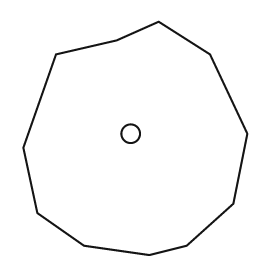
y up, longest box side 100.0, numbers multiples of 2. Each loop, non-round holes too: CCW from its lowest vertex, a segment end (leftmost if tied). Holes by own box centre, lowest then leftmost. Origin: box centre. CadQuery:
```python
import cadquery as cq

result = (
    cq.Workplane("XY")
    .moveTo(6.0, -50.0)
    .lineTo(22.0, -46.0)
    .lineTo(42.0, -28.0)
    .lineTo(48.0, 2.0)
    .lineTo(32.0, 36.0)
    .lineTo(10.0, 50.0)
    .lineTo(-8.0, 42.0)
    .lineTo(-34.0, 36.0)
    .lineTo(-48.0, -4.0)
    .lineTo(-42.0, -32.0)
    .lineTo(-22.0, -46.0)
    .close()
    .moveTo(-2.0, 2.0)
    .circle(4.0)
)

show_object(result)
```